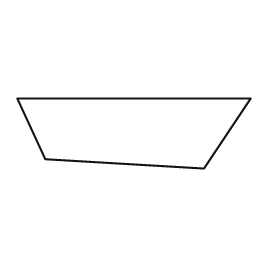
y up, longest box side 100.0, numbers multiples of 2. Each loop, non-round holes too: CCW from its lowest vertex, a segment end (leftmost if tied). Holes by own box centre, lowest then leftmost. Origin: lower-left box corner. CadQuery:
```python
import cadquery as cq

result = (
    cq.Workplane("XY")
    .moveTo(80.0, 0.0)
    .lineTo(100.0, 30.0)
    .lineTo(0.0, 30.0)
    .lineTo(12.0, 4.0)
    .close()
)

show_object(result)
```